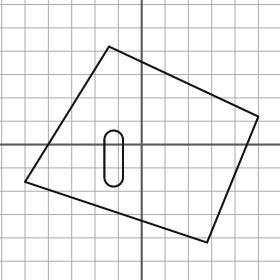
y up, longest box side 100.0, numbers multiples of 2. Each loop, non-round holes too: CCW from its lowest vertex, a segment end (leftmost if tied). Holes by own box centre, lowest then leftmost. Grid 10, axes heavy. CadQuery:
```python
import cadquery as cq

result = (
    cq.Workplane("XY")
    .moveTo(28.0, -42.0)
    .lineTo(50.0, 12.0)
    .lineTo(-14.0, 42.0)
    .lineTo(-50.0, -16.0)
    .close()
    .moveTo(-16.0, -14.0)
    .threePointArc((-12.0, -18.0), (-8.0, -14.0))
    .lineTo(-8.0, 2.0)
    .threePointArc((-12.0, 6.0), (-16.0, 2.0))
    .close()
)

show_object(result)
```